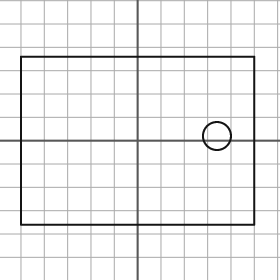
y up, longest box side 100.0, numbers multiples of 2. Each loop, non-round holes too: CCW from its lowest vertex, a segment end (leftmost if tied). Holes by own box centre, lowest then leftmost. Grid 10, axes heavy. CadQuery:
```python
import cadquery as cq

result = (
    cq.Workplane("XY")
    .moveTo(-50.0, -36.0)
    .lineTo(50.0, -36.0)
    .lineTo(50.0, 36.0)
    .lineTo(-50.0, 36.0)
    .close()
    .moveTo(34.0, 2.0)
    .circle(6.0)
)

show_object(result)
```